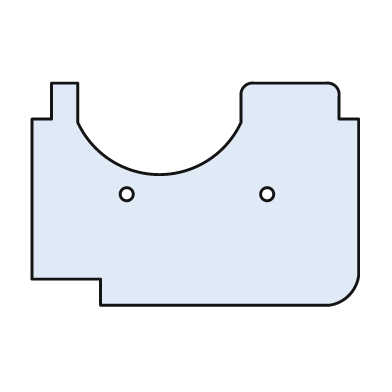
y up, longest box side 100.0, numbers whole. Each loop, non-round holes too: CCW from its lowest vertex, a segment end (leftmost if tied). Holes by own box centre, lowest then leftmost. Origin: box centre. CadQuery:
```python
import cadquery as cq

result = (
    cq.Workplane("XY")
    .moveTo(-29.0, -34.0)
    .lineTo(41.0, -34.0)
    .threePointArc((47.0, -31.0), (50.0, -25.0))
    .lineTo(50.0, 23.0)
    .lineTo(44.0, 23.0)
    .lineTo(44.0, 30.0)
    .threePointArc((43.0, 33.0), (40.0, 34.0))
    .lineTo(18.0, 34.0)
    .threePointArc((15.0, 33.0), (14.0, 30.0))
    .lineTo(14.0, 22.0)
    .threePointArc((-11.0, 6.0), (-36.0, 22.0))
    .lineTo(-36.0, 34.0)
    .lineTo(-44.0, 34.0)
    .lineTo(-44.0, 23.0)
    .lineTo(-50.0, 23.0)
    .lineTo(-50.0, -26.0)
    .lineTo(-29.0, -26.0)
    .close()
    .moveTo(-21.0, 0.0)
    .circle(2.0)
    .moveTo(22.0, 0.0)
    .circle(2.0)
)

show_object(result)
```